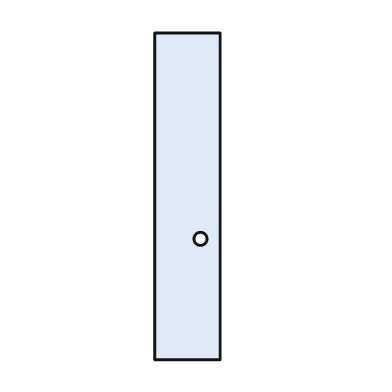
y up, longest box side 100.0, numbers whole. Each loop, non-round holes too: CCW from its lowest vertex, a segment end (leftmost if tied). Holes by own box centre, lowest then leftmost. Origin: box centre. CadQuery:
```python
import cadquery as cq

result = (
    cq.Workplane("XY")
    .moveTo(-10.0, -50.0)
    .lineTo(10.0, -50.0)
    .lineTo(10.0, 50.0)
    .lineTo(-10.0, 50.0)
    .close()
    .moveTo(4.0, -13.0)
    .circle(2.0)
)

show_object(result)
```